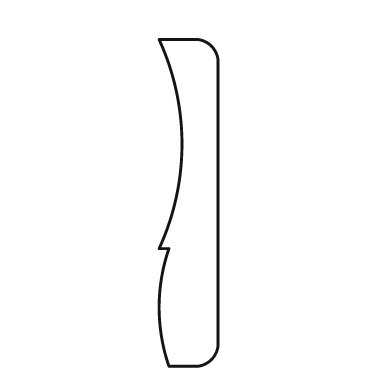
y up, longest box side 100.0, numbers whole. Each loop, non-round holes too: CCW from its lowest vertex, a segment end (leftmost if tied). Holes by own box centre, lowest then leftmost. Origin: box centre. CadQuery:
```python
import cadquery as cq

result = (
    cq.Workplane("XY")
    .moveTo(-6.0, -50.0)
    .lineTo(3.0, -50.0)
    .threePointArc((7.0, -48.0), (9.0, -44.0))
    .lineTo(9.0, 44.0)
    .threePointArc((7.0, 48.0), (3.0, 50.0))
    .lineTo(-9.0, 50.0)
    .threePointArc((-2.0, 18.0), (-9.0, -14.0))
    .lineTo(-6.0, -14.0)
    .threePointArc((-9.0, -32.0), (-6.0, -50.0))
    .close()
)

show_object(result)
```